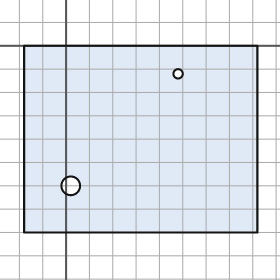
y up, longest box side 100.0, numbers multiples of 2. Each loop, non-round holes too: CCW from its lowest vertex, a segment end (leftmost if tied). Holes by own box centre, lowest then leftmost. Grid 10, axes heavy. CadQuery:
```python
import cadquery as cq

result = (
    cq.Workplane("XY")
    .moveTo(-18.0, -80.0)
    .lineTo(82.0, -80.0)
    .lineTo(82.0, 0.0)
    .lineTo(-18.0, 0.0)
    .close()
    .moveTo(2.0, -60.0)
    .circle(4.0)
    .moveTo(48.0, -12.0)
    .circle(2.0)
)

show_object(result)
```